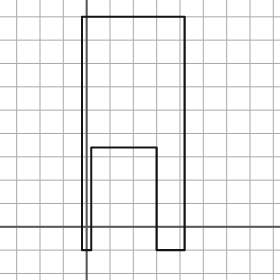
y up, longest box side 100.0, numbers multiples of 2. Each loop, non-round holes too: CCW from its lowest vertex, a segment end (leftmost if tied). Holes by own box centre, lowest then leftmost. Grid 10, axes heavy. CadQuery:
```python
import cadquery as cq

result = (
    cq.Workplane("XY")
    .moveTo(-2.0, -10.0)
    .lineTo(2.0, -10.0)
    .lineTo(2.0, 34.0)
    .lineTo(30.0, 34.0)
    .lineTo(30.0, -10.0)
    .lineTo(42.0, -10.0)
    .lineTo(42.0, 90.0)
    .lineTo(-2.0, 90.0)
    .close()
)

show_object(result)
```